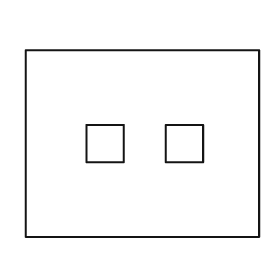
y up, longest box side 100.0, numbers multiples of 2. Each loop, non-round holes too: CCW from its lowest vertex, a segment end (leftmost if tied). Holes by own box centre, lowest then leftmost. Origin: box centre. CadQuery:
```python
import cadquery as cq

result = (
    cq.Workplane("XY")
    .moveTo(-50.0, -40.0)
    .lineTo(50.0, -40.0)
    .lineTo(50.0, 40.0)
    .lineTo(-50.0, 40.0)
    .close()
    .moveTo(-24.0, -8.0)
    .lineTo(-8.0, -8.0)
    .lineTo(-8.0, 8.0)
    .lineTo(-24.0, 8.0)
    .close()
    .moveTo(10.0, -8.0)
    .lineTo(26.0, -8.0)
    .lineTo(26.0, 8.0)
    .lineTo(10.0, 8.0)
    .close()
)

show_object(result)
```